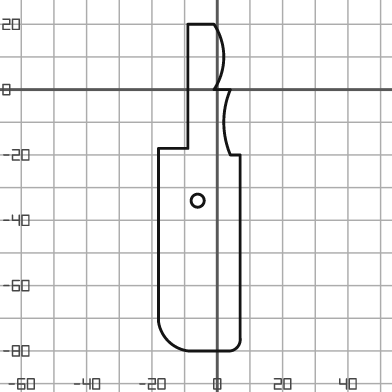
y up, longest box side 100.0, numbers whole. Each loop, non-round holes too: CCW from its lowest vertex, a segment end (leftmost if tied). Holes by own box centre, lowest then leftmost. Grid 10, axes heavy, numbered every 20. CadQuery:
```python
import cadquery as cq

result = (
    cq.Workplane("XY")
    .moveTo(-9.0, -80.0)
    .lineTo(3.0, -80.0)
    .threePointArc((6.0, -79.0), (7.0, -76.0))
    .lineTo(7.0, -20.0)
    .lineTo(4.0, -20.0)
    .threePointArc((2.0, -10.0), (4.0, 0.0))
    .lineTo(-1.0, 0.0)
    .threePointArc((2.0, 10.0), (-1.0, 20.0))
    .lineTo(-9.0, 20.0)
    .lineTo(-9.0, -18.0)
    .lineTo(-18.0, -18.0)
    .lineTo(-18.0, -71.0)
    .threePointArc((-15.0, -77.0), (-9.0, -80.0))
    .close()
    .moveTo(-6.0, -34.0)
    .circle(2.0)
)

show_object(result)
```